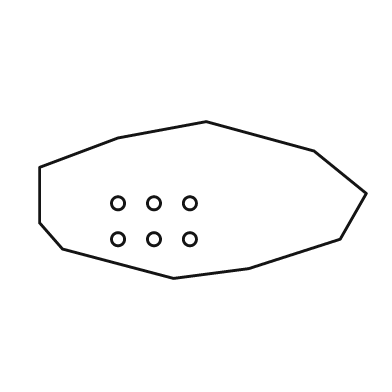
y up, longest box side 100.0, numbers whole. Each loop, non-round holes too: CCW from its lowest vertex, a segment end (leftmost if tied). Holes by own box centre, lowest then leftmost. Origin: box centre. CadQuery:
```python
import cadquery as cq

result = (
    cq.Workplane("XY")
    .moveTo(-9.0, -24.0)
    .lineTo(14.0, -21.0)
    .lineTo(42.0, -12.0)
    .lineTo(50.0, 2.0)
    .lineTo(34.0, 15.0)
    .lineTo(1.0, 24.0)
    .lineTo(-26.0, 19.0)
    .lineTo(-50.0, 10.0)
    .lineTo(-50.0, -7.0)
    .lineTo(-43.0, -15.0)
    .close()
    .moveTo(-26.0, -12.0)
    .circle(2.0)
    .moveTo(-15.0, -12.0)
    .circle(2.0)
    .moveTo(-4.0, -12.0)
    .circle(2.0)
    .moveTo(-26.0, -1.0)
    .circle(2.0)
    .moveTo(-15.0, -1.0)
    .circle(2.0)
    .moveTo(-4.0, -1.0)
    .circle(2.0)
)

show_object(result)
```